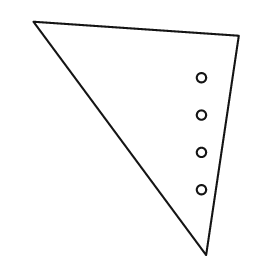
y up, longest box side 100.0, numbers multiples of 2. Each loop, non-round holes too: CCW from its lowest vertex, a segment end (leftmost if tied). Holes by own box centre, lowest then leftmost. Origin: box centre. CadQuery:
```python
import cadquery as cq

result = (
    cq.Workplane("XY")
    .moveTo(30.0, -50.0)
    .lineTo(44.0, 44.0)
    .lineTo(-44.0, 50.0)
    .close()
    .moveTo(28.0, -22.0)
    .circle(2.0)
    .moveTo(28.0, -6.0)
    .circle(2.0)
    .moveTo(28.0, 10.0)
    .circle(2.0)
    .moveTo(28.0, 26.0)
    .circle(2.0)
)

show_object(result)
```